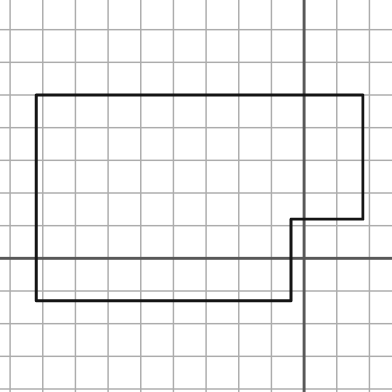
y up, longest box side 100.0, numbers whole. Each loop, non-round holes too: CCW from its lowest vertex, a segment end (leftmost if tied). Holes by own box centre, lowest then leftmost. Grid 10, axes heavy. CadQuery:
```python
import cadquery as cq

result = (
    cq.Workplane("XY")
    .moveTo(-82.0, -13.0)
    .lineTo(-4.0, -13.0)
    .lineTo(-4.0, 12.0)
    .lineTo(18.0, 12.0)
    .lineTo(18.0, 50.0)
    .lineTo(-82.0, 50.0)
    .close()
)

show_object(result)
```